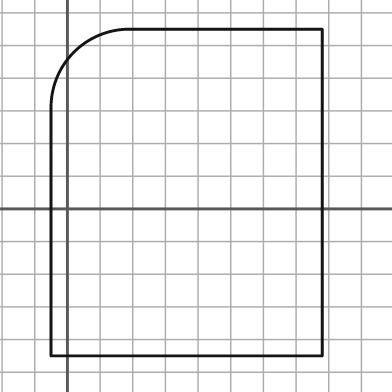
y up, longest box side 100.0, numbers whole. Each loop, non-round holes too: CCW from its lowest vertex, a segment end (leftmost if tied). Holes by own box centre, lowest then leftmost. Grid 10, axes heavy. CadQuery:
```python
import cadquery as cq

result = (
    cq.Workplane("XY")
    .moveTo(-5.0, -45.0)
    .lineTo(78.0, -45.0)
    .lineTo(78.0, 55.0)
    .lineTo(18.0, 55.0)
    .threePointArc((2.0, 48.0), (-5.0, 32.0))
    .close()
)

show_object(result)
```